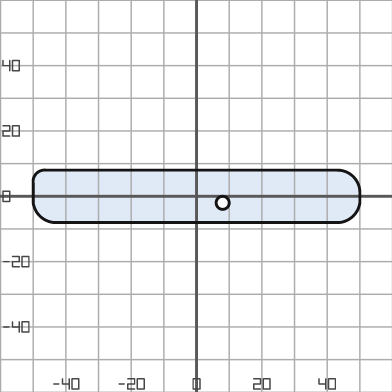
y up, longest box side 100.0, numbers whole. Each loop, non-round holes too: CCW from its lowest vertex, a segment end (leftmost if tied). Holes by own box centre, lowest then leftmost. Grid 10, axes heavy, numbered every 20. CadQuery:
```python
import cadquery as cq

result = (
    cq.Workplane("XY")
    .moveTo(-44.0, -8.0)
    .lineTo(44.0, -8.0)
    .threePointArc((48.0, -6.0), (50.0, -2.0))
    .lineTo(50.0, 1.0)
    .threePointArc((48.0, 6.0), (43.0, 8.0))
    .lineTo(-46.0, 8.0)
    .threePointArc((-49.0, 7.0), (-50.0, 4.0))
    .lineTo(-50.0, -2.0)
    .threePointArc((-48.0, -6.0), (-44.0, -8.0))
    .close()
    .moveTo(8.0, -2.0)
    .circle(2.0)
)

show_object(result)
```